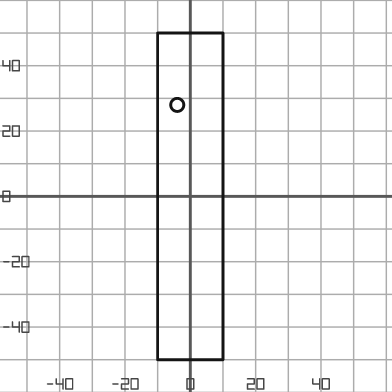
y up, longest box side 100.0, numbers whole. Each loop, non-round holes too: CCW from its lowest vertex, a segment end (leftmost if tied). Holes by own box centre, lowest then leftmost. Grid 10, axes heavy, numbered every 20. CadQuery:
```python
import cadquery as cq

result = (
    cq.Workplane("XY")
    .moveTo(-10.0, -50.0)
    .lineTo(10.0, -50.0)
    .lineTo(10.0, 50.0)
    .lineTo(-10.0, 50.0)
    .close()
    .moveTo(-4.0, 28.0)
    .circle(2.0)
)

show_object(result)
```